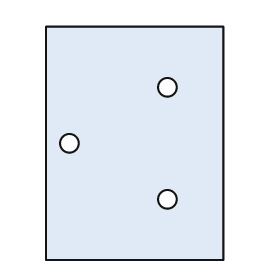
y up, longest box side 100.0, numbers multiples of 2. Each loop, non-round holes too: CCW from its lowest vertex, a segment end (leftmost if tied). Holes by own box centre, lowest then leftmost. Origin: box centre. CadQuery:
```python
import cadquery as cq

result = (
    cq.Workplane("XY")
    .moveTo(-38.0, -50.0)
    .lineTo(38.0, -50.0)
    .lineTo(38.0, 50.0)
    .lineTo(-38.0, 50.0)
    .close()
    .moveTo(14.0, -24.0)
    .circle(4.0)
    .moveTo(-28.0, 0.0)
    .circle(4.0)
    .moveTo(14.0, 24.0)
    .circle(4.0)
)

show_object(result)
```